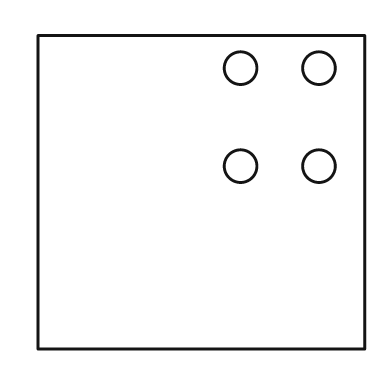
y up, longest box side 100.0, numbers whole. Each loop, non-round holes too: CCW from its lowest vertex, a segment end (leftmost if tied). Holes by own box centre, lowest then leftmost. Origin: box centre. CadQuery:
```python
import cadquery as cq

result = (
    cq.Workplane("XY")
    .moveTo(-50.0, -48.0)
    .lineTo(50.0, -48.0)
    .lineTo(50.0, 48.0)
    .lineTo(-50.0, 48.0)
    .close()
    .moveTo(12.0, 8.0)
    .circle(5.0)
    .moveTo(36.0, 8.0)
    .circle(5.0)
    .moveTo(12.0, 38.0)
    .circle(5.0)
    .moveTo(36.0, 38.0)
    .circle(5.0)
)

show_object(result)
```